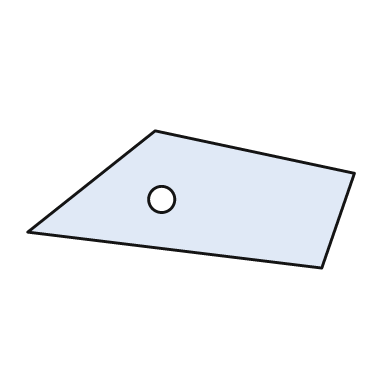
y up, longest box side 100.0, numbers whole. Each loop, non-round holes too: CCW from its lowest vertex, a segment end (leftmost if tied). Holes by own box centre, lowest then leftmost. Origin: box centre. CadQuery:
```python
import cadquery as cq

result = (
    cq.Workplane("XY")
    .moveTo(40.0, -21.0)
    .lineTo(50.0, 8.0)
    .lineTo(-11.0, 21.0)
    .lineTo(-50.0, -10.0)
    .close()
    .moveTo(-9.0, 0.0)
    .circle(4.0)
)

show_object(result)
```